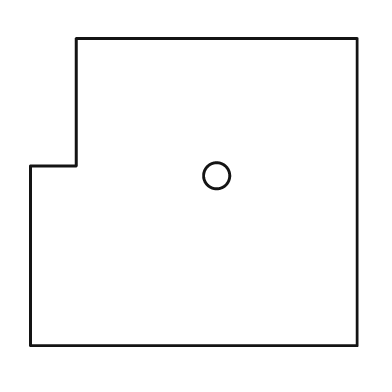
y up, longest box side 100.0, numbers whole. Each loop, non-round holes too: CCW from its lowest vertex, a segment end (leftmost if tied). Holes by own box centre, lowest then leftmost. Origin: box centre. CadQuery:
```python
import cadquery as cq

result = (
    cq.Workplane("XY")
    .moveTo(-50.0, -47.0)
    .lineTo(50.0, -47.0)
    .lineTo(50.0, 47.0)
    .lineTo(-36.0, 47.0)
    .lineTo(-36.0, 8.0)
    .lineTo(-50.0, 8.0)
    .close()
    .moveTo(7.0, 5.0)
    .circle(4.0)
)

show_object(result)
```